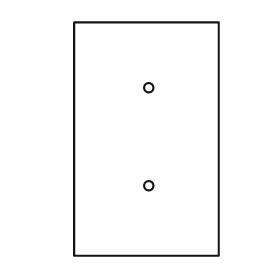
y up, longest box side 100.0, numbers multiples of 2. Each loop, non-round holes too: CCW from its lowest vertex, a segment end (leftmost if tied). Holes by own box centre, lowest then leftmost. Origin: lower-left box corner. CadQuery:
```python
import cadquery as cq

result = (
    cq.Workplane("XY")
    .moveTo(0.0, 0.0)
    .lineTo(62.0, 0.0)
    .lineTo(62.0, 100.0)
    .lineTo(0.0, 100.0)
    .close()
    .moveTo(32.0, 30.0)
    .circle(2.0)
    .moveTo(32.0, 72.0)
    .circle(2.0)
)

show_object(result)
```